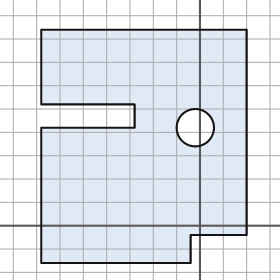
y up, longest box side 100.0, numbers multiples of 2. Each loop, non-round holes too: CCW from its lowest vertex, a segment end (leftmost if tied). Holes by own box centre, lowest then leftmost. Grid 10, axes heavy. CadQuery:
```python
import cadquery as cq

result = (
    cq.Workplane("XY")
    .moveTo(-68.0, -16.0)
    .lineTo(-4.0, -16.0)
    .lineTo(-4.0, -4.0)
    .lineTo(20.0, -4.0)
    .lineTo(20.0, 84.0)
    .lineTo(-68.0, 84.0)
    .lineTo(-68.0, 52.0)
    .lineTo(-28.0, 52.0)
    .lineTo(-28.0, 42.0)
    .lineTo(-68.0, 42.0)
    .close()
    .moveTo(-2.0, 42.0)
    .circle(8.0)
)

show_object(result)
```